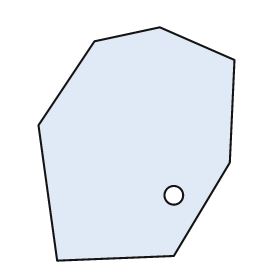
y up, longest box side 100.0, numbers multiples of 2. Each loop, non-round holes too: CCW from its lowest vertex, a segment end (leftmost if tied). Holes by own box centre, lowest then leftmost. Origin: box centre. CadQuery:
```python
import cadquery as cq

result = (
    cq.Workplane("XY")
    .moveTo(-34.0, -50.0)
    .lineTo(16.0, -48.0)
    .lineTo(40.0, -8.0)
    .lineTo(42.0, 36.0)
    .lineTo(10.0, 50.0)
    .lineTo(-18.0, 44.0)
    .lineTo(-42.0, 8.0)
    .close()
    .moveTo(16.0, -22.0)
    .circle(4.0)
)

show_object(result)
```